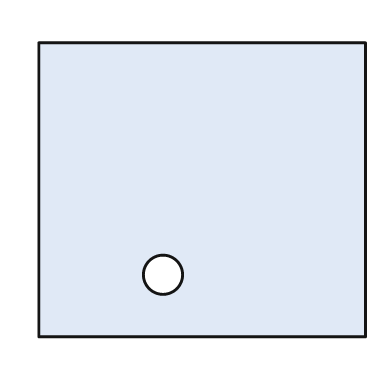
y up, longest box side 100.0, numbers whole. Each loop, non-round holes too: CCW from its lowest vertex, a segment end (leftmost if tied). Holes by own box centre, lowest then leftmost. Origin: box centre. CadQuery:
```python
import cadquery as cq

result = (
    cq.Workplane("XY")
    .moveTo(-50.0, -45.0)
    .lineTo(50.0, -45.0)
    .lineTo(50.0, 45.0)
    .lineTo(-50.0, 45.0)
    .close()
    .moveTo(-12.0, -26.0)
    .circle(6.0)
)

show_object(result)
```